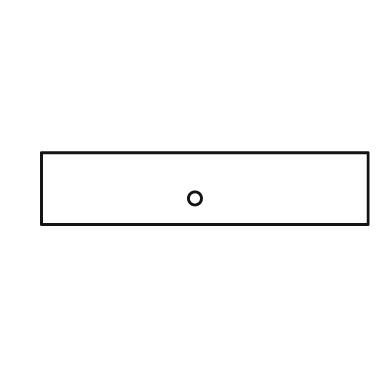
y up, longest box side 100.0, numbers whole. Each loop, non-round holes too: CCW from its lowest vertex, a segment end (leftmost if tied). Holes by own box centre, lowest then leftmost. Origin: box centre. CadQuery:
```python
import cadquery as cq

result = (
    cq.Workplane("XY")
    .moveTo(-50.0, -11.0)
    .lineTo(50.0, -11.0)
    .lineTo(50.0, 11.0)
    .lineTo(-50.0, 11.0)
    .close()
    .moveTo(-3.0, -3.0)
    .circle(2.0)
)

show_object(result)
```